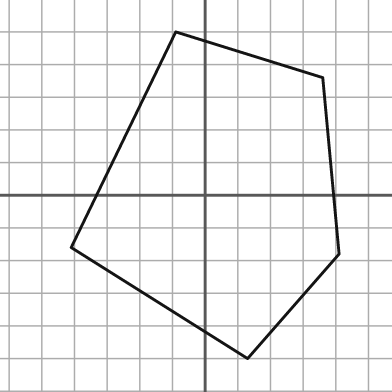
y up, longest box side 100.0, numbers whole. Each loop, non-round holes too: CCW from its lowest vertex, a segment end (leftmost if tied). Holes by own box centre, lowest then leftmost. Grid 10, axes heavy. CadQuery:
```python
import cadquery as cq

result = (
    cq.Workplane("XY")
    .moveTo(13.0, -50.0)
    .lineTo(41.0, -18.0)
    .lineTo(36.0, 36.0)
    .lineTo(-9.0, 50.0)
    .lineTo(-41.0, -16.0)
    .close()
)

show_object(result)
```